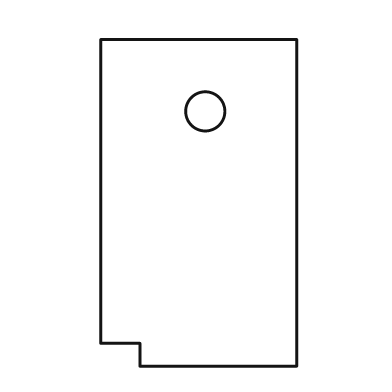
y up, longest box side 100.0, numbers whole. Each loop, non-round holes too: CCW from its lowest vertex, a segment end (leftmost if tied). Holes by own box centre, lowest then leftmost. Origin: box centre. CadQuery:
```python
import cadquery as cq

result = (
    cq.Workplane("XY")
    .moveTo(-18.0, -50.0)
    .lineTo(30.0, -50.0)
    .lineTo(30.0, 50.0)
    .lineTo(-30.0, 50.0)
    .lineTo(-30.0, -43.0)
    .lineTo(-18.0, -43.0)
    .close()
    .moveTo(2.0, 28.0)
    .circle(6.0)
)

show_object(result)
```